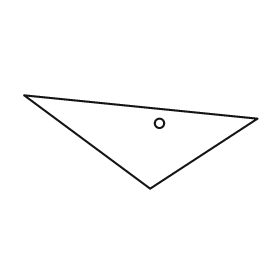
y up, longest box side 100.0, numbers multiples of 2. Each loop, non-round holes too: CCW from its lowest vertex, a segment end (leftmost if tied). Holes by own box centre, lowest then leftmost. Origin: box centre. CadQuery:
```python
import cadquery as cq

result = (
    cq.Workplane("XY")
    .moveTo(4.0, -20.0)
    .lineTo(50.0, 10.0)
    .lineTo(-50.0, 20.0)
    .close()
    .moveTo(8.0, 8.0)
    .circle(2.0)
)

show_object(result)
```